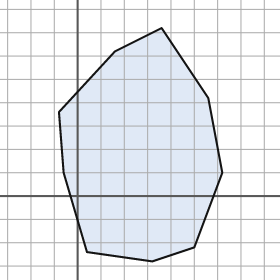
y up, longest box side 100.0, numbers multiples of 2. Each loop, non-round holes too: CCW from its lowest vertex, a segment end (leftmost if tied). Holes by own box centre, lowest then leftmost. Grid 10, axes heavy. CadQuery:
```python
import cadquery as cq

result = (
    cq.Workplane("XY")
    .moveTo(32.0, -28.0)
    .lineTo(50.0, -22.0)
    .lineTo(62.0, 10.0)
    .lineTo(56.0, 42.0)
    .lineTo(36.0, 72.0)
    .lineTo(16.0, 62.0)
    .lineTo(-8.0, 36.0)
    .lineTo(-6.0, 10.0)
    .lineTo(4.0, -24.0)
    .close()
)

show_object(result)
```